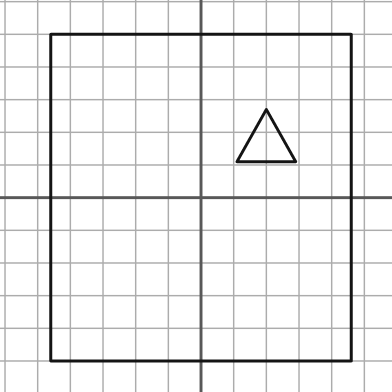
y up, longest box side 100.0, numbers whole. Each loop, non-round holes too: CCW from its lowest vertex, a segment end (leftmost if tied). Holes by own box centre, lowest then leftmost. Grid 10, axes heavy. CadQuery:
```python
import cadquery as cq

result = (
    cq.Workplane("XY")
    .moveTo(-46.0, -50.0)
    .lineTo(46.0, -50.0)
    .lineTo(46.0, 50.0)
    .lineTo(-46.0, 50.0)
    .close()
    .moveTo(11.0, 11.0)
    .lineTo(29.0, 11.0)
    .lineTo(20.0, 27.0)
    .close()
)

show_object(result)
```